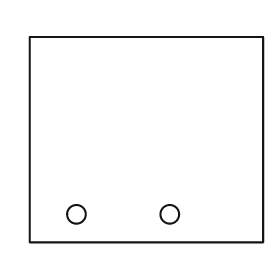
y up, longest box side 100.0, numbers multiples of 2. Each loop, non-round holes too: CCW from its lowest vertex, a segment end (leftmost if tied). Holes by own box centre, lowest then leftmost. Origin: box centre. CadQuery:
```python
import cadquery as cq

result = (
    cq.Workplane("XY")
    .moveTo(-50.0, -44.0)
    .lineTo(50.0, -44.0)
    .lineTo(50.0, 44.0)
    .lineTo(-50.0, 44.0)
    .close()
    .moveTo(-30.0, -32.0)
    .circle(4.0)
    .moveTo(10.0, -32.0)
    .circle(4.0)
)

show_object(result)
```